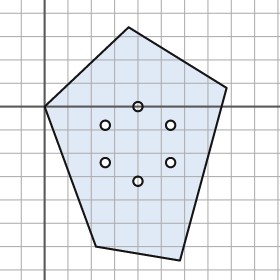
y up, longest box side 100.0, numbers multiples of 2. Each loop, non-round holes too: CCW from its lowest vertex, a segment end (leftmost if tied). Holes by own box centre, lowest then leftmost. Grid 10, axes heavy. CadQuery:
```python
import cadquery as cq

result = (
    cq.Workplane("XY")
    .moveTo(58.0, -66.0)
    .lineTo(78.0, 8.0)
    .lineTo(36.0, 34.0)
    .lineTo(0.0, 0.0)
    .lineTo(22.0, -60.0)
    .close()
    .moveTo(40.0, -32.0)
    .circle(2.0)
    .moveTo(26.0, -24.0)
    .circle(2.0)
    .moveTo(54.0, -24.0)
    .circle(2.0)
    .moveTo(26.0, -8.0)
    .circle(2.0)
    .moveTo(54.0, -8.0)
    .circle(2.0)
    .moveTo(40.0, 0.0)
    .circle(2.0)
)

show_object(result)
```